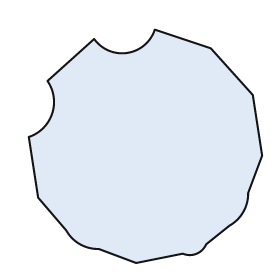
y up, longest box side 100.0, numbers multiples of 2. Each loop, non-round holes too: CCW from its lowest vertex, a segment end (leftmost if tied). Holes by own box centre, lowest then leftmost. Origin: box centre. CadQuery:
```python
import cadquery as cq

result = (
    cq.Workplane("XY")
    .moveTo(-4.0, -50.0)
    .lineTo(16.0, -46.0)
    .threePointArc((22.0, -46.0), (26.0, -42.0))
    .lineTo(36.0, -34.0)
    .threePointArc((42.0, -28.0), (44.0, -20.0))
    .lineTo(50.0, -4.0)
    .lineTo(46.0, 22.0)
    .lineTo(28.0, 42.0)
    .lineTo(4.0, 50.0)
    .threePointArc((-8.0, 40.0), (-22.0, 46.0))
    .lineTo(-42.0, 28.0)
    .threePointArc((-40.0, 14.0), (-50.0, 4.0))
    .lineTo(-46.0, -22.0)
    .lineTo(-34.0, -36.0)
    .threePointArc((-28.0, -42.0), (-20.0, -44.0))
    .close()
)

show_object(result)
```